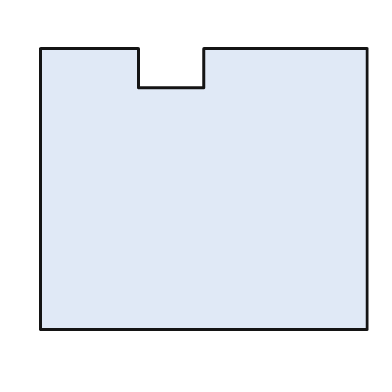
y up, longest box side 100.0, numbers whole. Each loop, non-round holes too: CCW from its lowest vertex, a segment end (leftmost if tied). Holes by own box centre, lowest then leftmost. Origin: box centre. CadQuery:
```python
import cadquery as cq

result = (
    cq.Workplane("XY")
    .moveTo(-50.0, -43.0)
    .lineTo(50.0, -43.0)
    .lineTo(50.0, 43.0)
    .lineTo(0.0, 43.0)
    .lineTo(0.0, 31.0)
    .lineTo(-20.0, 31.0)
    .lineTo(-20.0, 43.0)
    .lineTo(-50.0, 43.0)
    .close()
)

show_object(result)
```